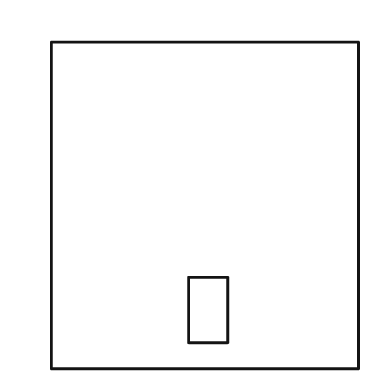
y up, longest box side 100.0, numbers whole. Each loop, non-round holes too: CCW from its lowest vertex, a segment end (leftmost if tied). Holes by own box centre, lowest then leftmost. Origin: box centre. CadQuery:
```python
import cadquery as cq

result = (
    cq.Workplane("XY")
    .moveTo(-47.0, -50.0)
    .lineTo(47.0, -50.0)
    .lineTo(47.0, 50.0)
    .lineTo(-47.0, 50.0)
    .close()
    .moveTo(-5.0, -42.0)
    .lineTo(7.0, -42.0)
    .lineTo(7.0, -22.0)
    .lineTo(-5.0, -22.0)
    .close()
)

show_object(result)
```